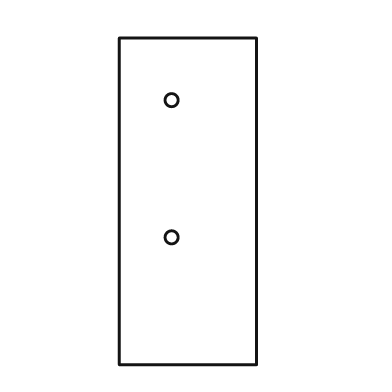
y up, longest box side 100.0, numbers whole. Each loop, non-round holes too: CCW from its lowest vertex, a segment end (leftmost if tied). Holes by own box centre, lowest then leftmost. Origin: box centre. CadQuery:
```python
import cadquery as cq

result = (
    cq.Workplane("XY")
    .moveTo(-21.0, -50.0)
    .lineTo(21.0, -50.0)
    .lineTo(21.0, 50.0)
    .lineTo(-21.0, 50.0)
    .close()
    .moveTo(-5.0, -11.0)
    .circle(2.0)
    .moveTo(-5.0, 31.0)
    .circle(2.0)
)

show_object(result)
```